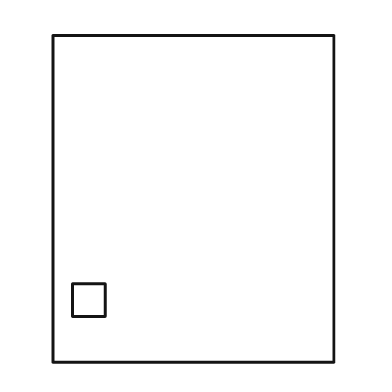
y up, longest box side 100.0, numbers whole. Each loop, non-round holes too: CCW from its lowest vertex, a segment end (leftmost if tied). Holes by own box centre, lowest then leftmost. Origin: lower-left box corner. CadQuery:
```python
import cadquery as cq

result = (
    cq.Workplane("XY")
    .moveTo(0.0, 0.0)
    .lineTo(86.0, 0.0)
    .lineTo(86.0, 100.0)
    .lineTo(0.0, 100.0)
    .close()
    .moveTo(6.0, 14.0)
    .lineTo(16.0, 14.0)
    .lineTo(16.0, 24.0)
    .lineTo(6.0, 24.0)
    .close()
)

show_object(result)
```